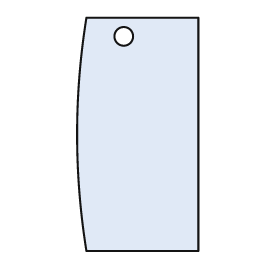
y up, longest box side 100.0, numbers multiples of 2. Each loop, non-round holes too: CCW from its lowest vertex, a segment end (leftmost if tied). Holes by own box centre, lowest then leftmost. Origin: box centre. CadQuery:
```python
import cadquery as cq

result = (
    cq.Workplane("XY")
    .moveTo(-22.0, -50.0)
    .lineTo(26.0, -50.0)
    .lineTo(26.0, 50.0)
    .lineTo(-22.0, 50.0)
    .threePointArc((-26.0, 0.0), (-22.0, -50.0))
    .close()
    .moveTo(-6.0, 42.0)
    .circle(4.0)
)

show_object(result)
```